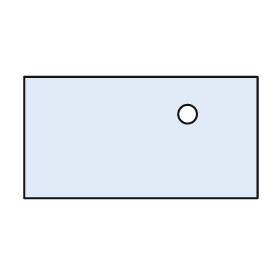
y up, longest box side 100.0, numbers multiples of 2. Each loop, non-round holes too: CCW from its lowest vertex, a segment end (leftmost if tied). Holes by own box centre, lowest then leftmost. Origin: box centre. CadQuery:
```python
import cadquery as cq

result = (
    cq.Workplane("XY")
    .moveTo(-50.0, -26.0)
    .lineTo(50.0, -26.0)
    .lineTo(50.0, 26.0)
    .lineTo(-50.0, 26.0)
    .close()
    .moveTo(20.0, 10.0)
    .circle(4.0)
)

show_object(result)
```